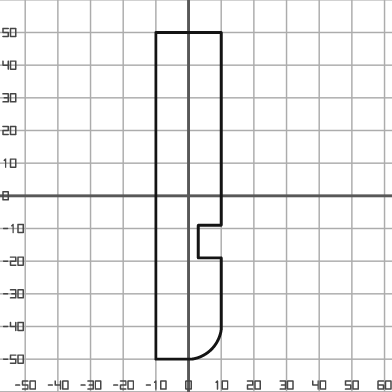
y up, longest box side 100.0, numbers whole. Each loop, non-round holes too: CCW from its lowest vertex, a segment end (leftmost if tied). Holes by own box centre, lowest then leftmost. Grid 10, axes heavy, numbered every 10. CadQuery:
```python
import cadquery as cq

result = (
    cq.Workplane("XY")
    .moveTo(-10.0, -50.0)
    .lineTo(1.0, -50.0)
    .threePointArc((7.0, -47.0), (10.0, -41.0))
    .lineTo(10.0, -19.0)
    .lineTo(3.0, -19.0)
    .lineTo(3.0, -9.0)
    .lineTo(10.0, -9.0)
    .lineTo(10.0, 50.0)
    .lineTo(-10.0, 50.0)
    .close()
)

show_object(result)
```